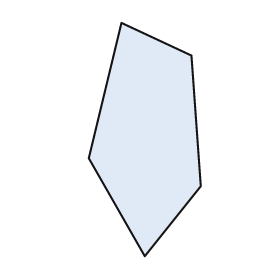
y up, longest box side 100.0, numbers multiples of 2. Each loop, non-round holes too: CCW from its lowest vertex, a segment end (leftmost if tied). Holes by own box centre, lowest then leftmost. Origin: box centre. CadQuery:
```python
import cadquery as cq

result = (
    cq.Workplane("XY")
    .moveTo(0.0, -50.0)
    .lineTo(24.0, -20.0)
    .lineTo(20.0, 36.0)
    .lineTo(-10.0, 50.0)
    .lineTo(-24.0, -8.0)
    .close()
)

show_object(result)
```